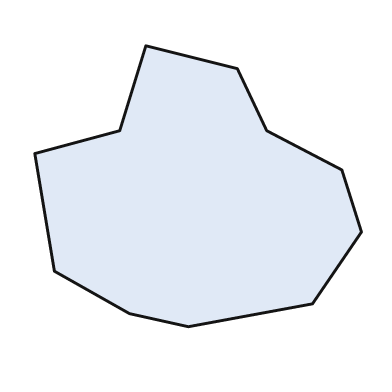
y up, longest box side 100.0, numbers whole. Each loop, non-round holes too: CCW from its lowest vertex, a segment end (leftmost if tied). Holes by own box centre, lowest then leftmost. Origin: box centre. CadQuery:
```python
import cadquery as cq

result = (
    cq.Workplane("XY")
    .moveTo(-3.0, -43.0)
    .lineTo(35.0, -36.0)
    .lineTo(50.0, -14.0)
    .lineTo(44.0, 5.0)
    .lineTo(21.0, 17.0)
    .lineTo(12.0, 36.0)
    .lineTo(-16.0, 43.0)
    .lineTo(-24.0, 17.0)
    .lineTo(-50.0, 10.0)
    .lineTo(-44.0, -26.0)
    .lineTo(-21.0, -39.0)
    .close()
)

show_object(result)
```